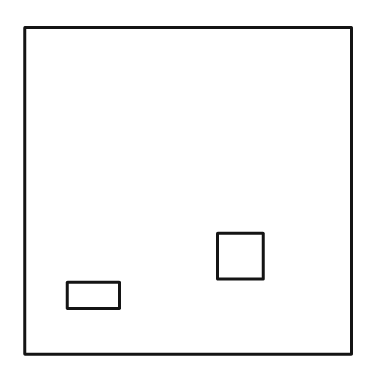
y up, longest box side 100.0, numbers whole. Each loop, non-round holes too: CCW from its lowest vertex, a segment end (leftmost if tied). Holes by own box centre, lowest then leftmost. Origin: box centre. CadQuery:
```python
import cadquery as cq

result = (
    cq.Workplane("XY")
    .moveTo(-50.0, -50.0)
    .lineTo(50.0, -50.0)
    .lineTo(50.0, 50.0)
    .lineTo(-50.0, 50.0)
    .close()
    .moveTo(-37.0, -36.0)
    .lineTo(-21.0, -36.0)
    .lineTo(-21.0, -28.0)
    .lineTo(-37.0, -28.0)
    .close()
    .moveTo(9.0, -27.0)
    .lineTo(23.0, -27.0)
    .lineTo(23.0, -13.0)
    .lineTo(9.0, -13.0)
    .close()
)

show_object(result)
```